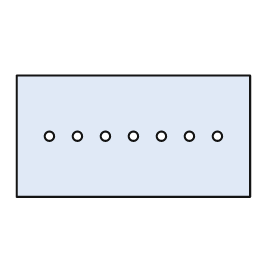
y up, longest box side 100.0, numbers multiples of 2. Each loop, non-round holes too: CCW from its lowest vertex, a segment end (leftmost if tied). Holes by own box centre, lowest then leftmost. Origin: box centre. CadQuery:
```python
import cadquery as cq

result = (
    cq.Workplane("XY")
    .moveTo(-50.0, -26.0)
    .lineTo(50.0, -26.0)
    .lineTo(50.0, 26.0)
    .lineTo(-50.0, 26.0)
    .close()
    .moveTo(-36.0, 0.0)
    .circle(2.0)
    .moveTo(-24.0, 0.0)
    .circle(2.0)
    .moveTo(-12.0, 0.0)
    .circle(2.0)
    .moveTo(0.0, 0.0)
    .circle(2.0)
    .moveTo(12.0, 0.0)
    .circle(2.0)
    .moveTo(24.0, 0.0)
    .circle(2.0)
    .moveTo(36.0, 0.0)
    .circle(2.0)
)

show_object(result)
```